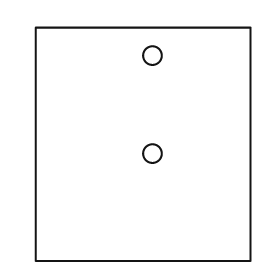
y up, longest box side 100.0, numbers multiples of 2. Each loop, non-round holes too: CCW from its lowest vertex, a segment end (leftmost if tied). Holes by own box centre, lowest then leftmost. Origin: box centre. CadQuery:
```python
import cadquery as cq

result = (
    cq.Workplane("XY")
    .moveTo(-46.0, -50.0)
    .lineTo(46.0, -50.0)
    .lineTo(46.0, 50.0)
    .lineTo(-46.0, 50.0)
    .close()
    .moveTo(4.0, -4.0)
    .circle(4.0)
    .moveTo(4.0, 38.0)
    .circle(4.0)
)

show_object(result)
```